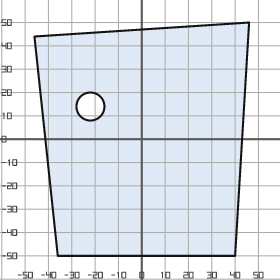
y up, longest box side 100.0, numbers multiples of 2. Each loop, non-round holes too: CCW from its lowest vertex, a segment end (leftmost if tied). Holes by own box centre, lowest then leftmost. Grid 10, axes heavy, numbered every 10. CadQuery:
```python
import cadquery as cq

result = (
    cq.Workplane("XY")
    .moveTo(-36.0, -50.0)
    .lineTo(40.0, -50.0)
    .lineTo(46.0, 50.0)
    .lineTo(-46.0, 44.0)
    .close()
    .moveTo(-22.0, 14.0)
    .circle(6.0)
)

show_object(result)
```